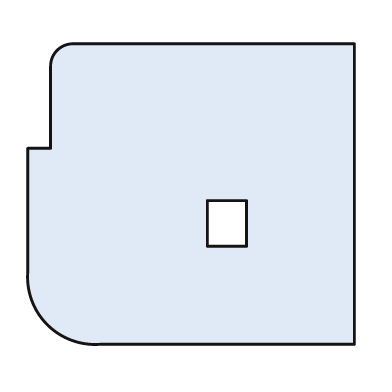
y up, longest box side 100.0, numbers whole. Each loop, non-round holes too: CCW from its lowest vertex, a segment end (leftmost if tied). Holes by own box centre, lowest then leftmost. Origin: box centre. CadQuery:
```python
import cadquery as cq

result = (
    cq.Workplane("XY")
    .moveTo(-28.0, -46.0)
    .lineTo(50.0, -46.0)
    .lineTo(50.0, 46.0)
    .lineTo(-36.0, 46.0)
    .threePointArc((-41.0, 44.0), (-43.0, 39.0))
    .lineTo(-43.0, 14.0)
    .lineTo(-50.0, 14.0)
    .lineTo(-50.0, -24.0)
    .threePointArc((-44.0, -40.0), (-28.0, -46.0))
    .close()
    .moveTo(5.0, -16.0)
    .lineTo(17.0, -16.0)
    .lineTo(17.0, -2.0)
    .lineTo(5.0, -2.0)
    .close()
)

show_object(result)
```